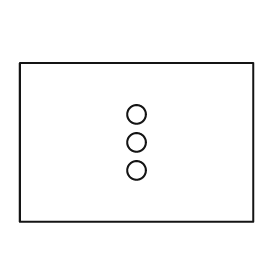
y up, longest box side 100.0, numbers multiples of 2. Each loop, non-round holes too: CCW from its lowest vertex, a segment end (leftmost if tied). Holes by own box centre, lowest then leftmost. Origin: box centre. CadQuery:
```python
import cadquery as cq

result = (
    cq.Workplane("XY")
    .moveTo(-50.0, -34.0)
    .lineTo(50.0, -34.0)
    .lineTo(50.0, 34.0)
    .lineTo(-50.0, 34.0)
    .close()
    .moveTo(0.0, -12.0)
    .circle(4.0)
    .moveTo(0.0, 0.0)
    .circle(4.0)
    .moveTo(0.0, 12.0)
    .circle(4.0)
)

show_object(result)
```